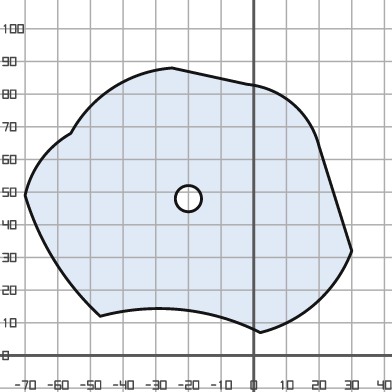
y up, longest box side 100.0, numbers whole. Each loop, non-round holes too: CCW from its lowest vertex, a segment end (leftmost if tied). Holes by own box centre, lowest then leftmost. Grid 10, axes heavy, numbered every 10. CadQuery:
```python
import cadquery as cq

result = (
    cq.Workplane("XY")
    .moveTo(2.0, 7.0)
    .threePointArc((19.0, 16.0), (30.0, 32.0))
    .lineTo(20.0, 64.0)
    .threePointArc((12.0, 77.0), (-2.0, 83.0))
    .lineTo(-25.0, 88.0)
    .threePointArc((-43.0, 82.0), (-56.0, 68.0))
    .threePointArc((-65.0, 60.0), (-70.0, 49.0))
    .threePointArc((-61.0, 29.0), (-47.0, 12.0))
    .threePointArc((-22.0, 14.0), (2.0, 7.0))
    .close()
    .moveTo(-20.0, 48.0)
    .circle(4.0)
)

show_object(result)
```